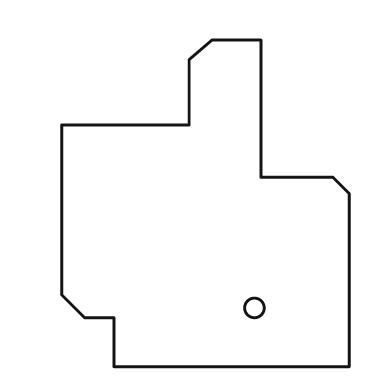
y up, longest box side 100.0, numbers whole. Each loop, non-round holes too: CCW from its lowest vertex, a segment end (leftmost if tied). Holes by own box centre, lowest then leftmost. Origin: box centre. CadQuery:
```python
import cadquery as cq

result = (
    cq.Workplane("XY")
    .moveTo(-28.0, -50.0)
    .lineTo(44.0, -50.0)
    .lineTo(44.0, 3.0)
    .lineTo(39.0, 8.0)
    .lineTo(17.0, 8.0)
    .lineTo(17.0, 50.0)
    .lineTo(2.0, 50.0)
    .lineTo(-5.0, 44.0)
    .lineTo(-5.0, 24.0)
    .lineTo(-44.0, 24.0)
    .lineTo(-44.0, -28.0)
    .lineTo(-37.0, -35.0)
    .lineTo(-28.0, -35.0)
    .close()
    .moveTo(15.0, -32.0)
    .circle(3.0)
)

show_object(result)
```